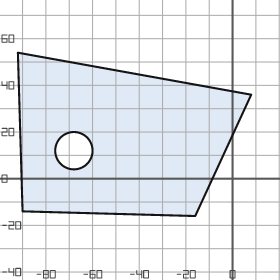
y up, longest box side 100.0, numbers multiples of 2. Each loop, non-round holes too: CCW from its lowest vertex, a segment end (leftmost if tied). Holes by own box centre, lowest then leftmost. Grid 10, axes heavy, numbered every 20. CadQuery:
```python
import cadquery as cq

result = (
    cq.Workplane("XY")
    .moveTo(-16.0, -16.0)
    .lineTo(8.0, 36.0)
    .lineTo(-92.0, 54.0)
    .lineTo(-90.0, -14.0)
    .close()
    .moveTo(-68.0, 12.0)
    .circle(8.0)
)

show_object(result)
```